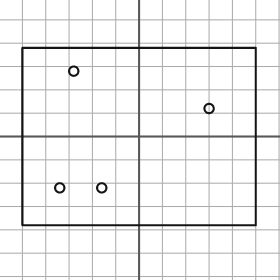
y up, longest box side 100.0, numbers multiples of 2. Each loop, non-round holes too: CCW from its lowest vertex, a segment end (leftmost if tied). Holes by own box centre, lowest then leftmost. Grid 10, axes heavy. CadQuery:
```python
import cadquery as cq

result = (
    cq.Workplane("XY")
    .moveTo(-50.0, -38.0)
    .lineTo(50.0, -38.0)
    .lineTo(50.0, 38.0)
    .lineTo(-50.0, 38.0)
    .close()
    .moveTo(-34.0, -22.0)
    .circle(2.0)
    .moveTo(-16.0, -22.0)
    .circle(2.0)
    .moveTo(30.0, 12.0)
    .circle(2.0)
    .moveTo(-28.0, 28.0)
    .circle(2.0)
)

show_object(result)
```